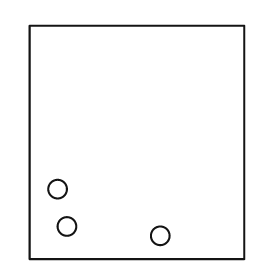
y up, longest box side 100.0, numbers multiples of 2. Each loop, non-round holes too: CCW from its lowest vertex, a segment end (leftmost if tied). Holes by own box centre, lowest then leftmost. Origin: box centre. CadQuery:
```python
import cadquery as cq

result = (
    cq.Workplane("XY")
    .moveTo(-46.0, -50.0)
    .lineTo(46.0, -50.0)
    .lineTo(46.0, 50.0)
    .lineTo(-46.0, 50.0)
    .close()
    .moveTo(10.0, -40.0)
    .circle(4.0)
    .moveTo(-30.0, -36.0)
    .circle(4.0)
    .moveTo(-34.0, -20.0)
    .circle(4.0)
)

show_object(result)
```